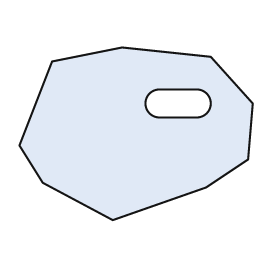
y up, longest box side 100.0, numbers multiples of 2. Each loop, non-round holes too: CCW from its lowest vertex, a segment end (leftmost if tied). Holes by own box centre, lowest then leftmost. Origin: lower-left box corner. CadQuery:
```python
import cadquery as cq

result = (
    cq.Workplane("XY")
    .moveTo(40.0, 0.0)
    .lineTo(80.0, 14.0)
    .lineTo(98.0, 26.0)
    .lineTo(100.0, 50.0)
    .lineTo(82.0, 70.0)
    .lineTo(44.0, 74.0)
    .lineTo(14.0, 68.0)
    .lineTo(0.0, 32.0)
    .lineTo(10.0, 16.0)
    .close()
    .moveTo(60.0, 44.0)
    .lineTo(76.0, 44.0)
    .threePointArc((82.0, 50.0), (76.0, 56.0))
    .lineTo(60.0, 56.0)
    .threePointArc((54.0, 50.0), (60.0, 44.0))
    .close()
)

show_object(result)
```